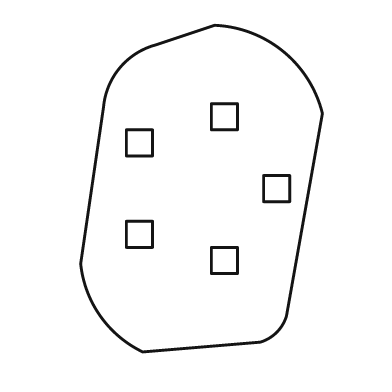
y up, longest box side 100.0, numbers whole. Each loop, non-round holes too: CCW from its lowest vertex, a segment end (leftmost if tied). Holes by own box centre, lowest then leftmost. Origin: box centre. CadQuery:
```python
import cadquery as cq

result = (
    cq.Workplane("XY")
    .moveTo(-18.0, -50.0)
    .lineTo(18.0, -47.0)
    .threePointArc((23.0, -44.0), (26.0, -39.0))
    .lineTo(37.0, 23.0)
    .threePointArc((25.0, 42.0), (4.0, 50.0))
    .lineTo(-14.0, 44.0)
    .threePointArc((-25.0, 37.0), (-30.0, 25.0))
    .lineTo(-37.0, -23.0)
    .threePointArc((-31.0, -39.0), (-18.0, -50.0))
    .close()
    .moveTo(3.0, -26.0)
    .lineTo(11.0, -26.0)
    .lineTo(11.0, -18.0)
    .lineTo(3.0, -18.0)
    .close()
    .moveTo(-23.0, -18.0)
    .lineTo(-15.0, -18.0)
    .lineTo(-15.0, -10.0)
    .lineTo(-23.0, -10.0)
    .close()
    .moveTo(19.0, -4.0)
    .lineTo(27.0, -4.0)
    .lineTo(27.0, 4.0)
    .lineTo(19.0, 4.0)
    .close()
    .moveTo(-23.0, 10.0)
    .lineTo(-15.0, 10.0)
    .lineTo(-15.0, 18.0)
    .lineTo(-23.0, 18.0)
    .close()
    .moveTo(3.0, 18.0)
    .lineTo(11.0, 18.0)
    .lineTo(11.0, 26.0)
    .lineTo(3.0, 26.0)
    .close()
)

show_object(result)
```